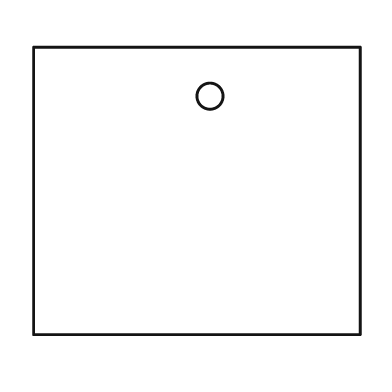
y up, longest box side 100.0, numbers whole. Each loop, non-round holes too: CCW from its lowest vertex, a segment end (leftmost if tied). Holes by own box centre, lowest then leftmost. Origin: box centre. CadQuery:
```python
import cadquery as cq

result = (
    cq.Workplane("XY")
    .moveTo(-50.0, -44.0)
    .lineTo(50.0, -44.0)
    .lineTo(50.0, 44.0)
    .lineTo(-50.0, 44.0)
    .close()
    .moveTo(4.0, 29.0)
    .circle(4.0)
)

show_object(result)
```